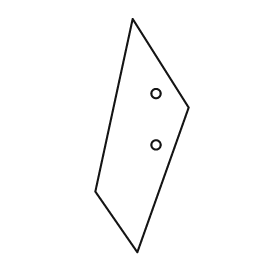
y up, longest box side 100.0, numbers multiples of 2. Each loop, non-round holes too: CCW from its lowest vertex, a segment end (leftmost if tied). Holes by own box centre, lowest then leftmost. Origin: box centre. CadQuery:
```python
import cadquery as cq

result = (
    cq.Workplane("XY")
    .moveTo(-2.0, -50.0)
    .lineTo(20.0, 12.0)
    .lineTo(-4.0, 50.0)
    .lineTo(-20.0, -24.0)
    .close()
    .moveTo(6.0, -4.0)
    .circle(2.0)
    .moveTo(6.0, 18.0)
    .circle(2.0)
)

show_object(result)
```